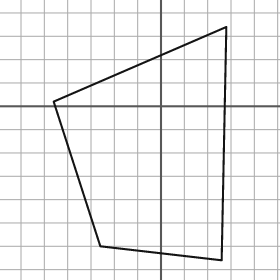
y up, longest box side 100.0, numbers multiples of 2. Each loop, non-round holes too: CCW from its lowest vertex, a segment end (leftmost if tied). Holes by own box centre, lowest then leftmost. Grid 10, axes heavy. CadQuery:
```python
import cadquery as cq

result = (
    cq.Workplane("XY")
    .moveTo(26.0, -66.0)
    .lineTo(28.0, 34.0)
    .lineTo(-46.0, 2.0)
    .lineTo(-26.0, -60.0)
    .close()
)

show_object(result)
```